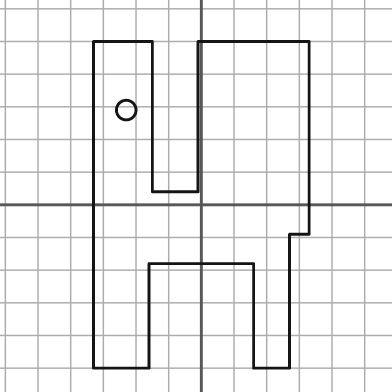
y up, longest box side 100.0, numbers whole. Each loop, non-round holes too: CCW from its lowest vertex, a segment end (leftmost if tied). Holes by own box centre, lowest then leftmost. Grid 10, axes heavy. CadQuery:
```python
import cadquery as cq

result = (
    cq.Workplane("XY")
    .moveTo(-33.0, -50.0)
    .lineTo(-16.0, -50.0)
    .lineTo(-16.0, -18.0)
    .lineTo(16.0, -18.0)
    .lineTo(16.0, -50.0)
    .lineTo(27.0, -50.0)
    .lineTo(27.0, -9.0)
    .lineTo(33.0, -9.0)
    .lineTo(33.0, 50.0)
    .lineTo(-1.0, 50.0)
    .lineTo(-1.0, 4.0)
    .lineTo(-15.0, 4.0)
    .lineTo(-15.0, 50.0)
    .lineTo(-33.0, 50.0)
    .close()
    .moveTo(-23.0, 29.0)
    .circle(3.0)
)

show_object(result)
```